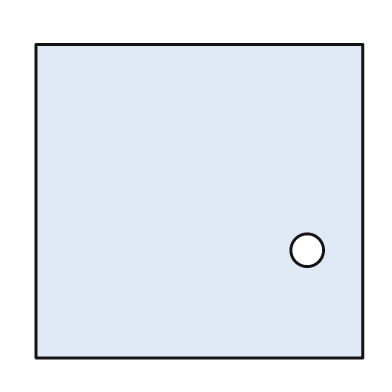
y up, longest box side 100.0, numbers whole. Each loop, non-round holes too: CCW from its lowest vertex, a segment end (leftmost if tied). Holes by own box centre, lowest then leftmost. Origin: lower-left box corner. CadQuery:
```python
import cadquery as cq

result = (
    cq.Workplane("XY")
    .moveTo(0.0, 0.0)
    .lineTo(100.0, 0.0)
    .lineTo(100.0, 96.0)
    .lineTo(0.0, 96.0)
    .close()
    .moveTo(83.0, 33.0)
    .circle(5.0)
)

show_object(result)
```